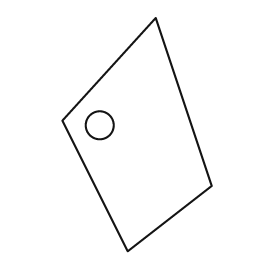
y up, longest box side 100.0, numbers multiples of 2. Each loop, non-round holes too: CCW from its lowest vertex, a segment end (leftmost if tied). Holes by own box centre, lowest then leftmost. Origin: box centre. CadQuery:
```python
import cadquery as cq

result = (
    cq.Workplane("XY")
    .moveTo(-4.0, -50.0)
    .lineTo(32.0, -22.0)
    .lineTo(8.0, 50.0)
    .lineTo(-32.0, 6.0)
    .close()
    .moveTo(-16.0, 4.0)
    .circle(6.0)
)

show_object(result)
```